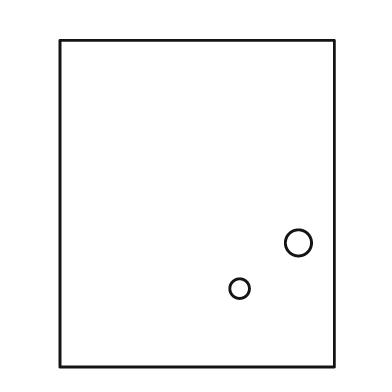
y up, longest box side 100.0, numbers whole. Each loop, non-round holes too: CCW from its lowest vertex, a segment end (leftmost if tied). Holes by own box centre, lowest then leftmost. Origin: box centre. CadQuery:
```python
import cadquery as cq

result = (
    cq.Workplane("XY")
    .moveTo(-42.0, -50.0)
    .lineTo(42.0, -50.0)
    .lineTo(42.0, 50.0)
    .lineTo(-42.0, 50.0)
    .close()
    .moveTo(13.0, -26.0)
    .circle(3.0)
    .moveTo(31.0, -12.0)
    .circle(4.0)
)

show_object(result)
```